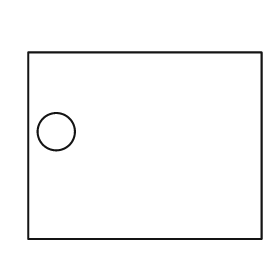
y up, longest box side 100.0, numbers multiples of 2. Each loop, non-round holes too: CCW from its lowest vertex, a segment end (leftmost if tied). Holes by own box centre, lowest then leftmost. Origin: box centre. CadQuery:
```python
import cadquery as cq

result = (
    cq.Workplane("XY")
    .moveTo(-50.0, -40.0)
    .lineTo(50.0, -40.0)
    .lineTo(50.0, 40.0)
    .lineTo(-50.0, 40.0)
    .close()
    .moveTo(-38.0, 6.0)
    .circle(8.0)
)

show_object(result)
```